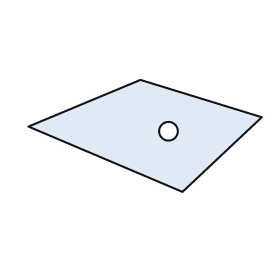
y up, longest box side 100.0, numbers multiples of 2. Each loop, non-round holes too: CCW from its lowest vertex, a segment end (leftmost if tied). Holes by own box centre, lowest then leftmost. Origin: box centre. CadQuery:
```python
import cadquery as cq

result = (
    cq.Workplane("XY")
    .moveTo(16.0, -24.0)
    .lineTo(50.0, 8.0)
    .lineTo(-2.0, 24.0)
    .lineTo(-50.0, 4.0)
    .close()
    .moveTo(10.0, 2.0)
    .circle(4.0)
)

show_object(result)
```